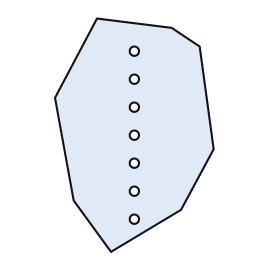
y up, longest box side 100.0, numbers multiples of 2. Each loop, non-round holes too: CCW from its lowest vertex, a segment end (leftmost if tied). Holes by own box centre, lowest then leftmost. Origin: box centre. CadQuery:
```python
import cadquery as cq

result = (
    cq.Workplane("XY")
    .moveTo(-10.0, -50.0)
    .lineTo(20.0, -32.0)
    .lineTo(34.0, -6.0)
    .lineTo(28.0, 38.0)
    .lineTo(16.0, 46.0)
    .lineTo(-16.0, 50.0)
    .lineTo(-34.0, 16.0)
    .lineTo(-26.0, -28.0)
    .close()
    .moveTo(0.0, -36.0)
    .circle(2.0)
    .moveTo(0.0, -24.0)
    .circle(2.0)
    .moveTo(0.0, -12.0)
    .circle(2.0)
    .moveTo(0.0, 0.0)
    .circle(2.0)
    .moveTo(0.0, 12.0)
    .circle(2.0)
    .moveTo(0.0, 24.0)
    .circle(2.0)
    .moveTo(0.0, 36.0)
    .circle(2.0)
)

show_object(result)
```